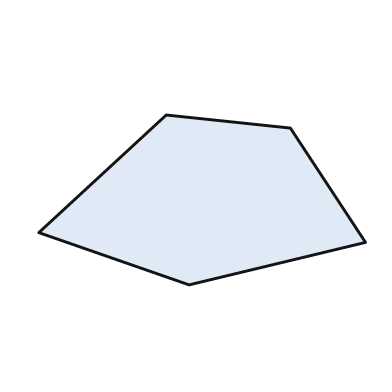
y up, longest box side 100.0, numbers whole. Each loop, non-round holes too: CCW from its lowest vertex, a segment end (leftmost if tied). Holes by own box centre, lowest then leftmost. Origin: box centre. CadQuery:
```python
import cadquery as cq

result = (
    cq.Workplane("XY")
    .moveTo(-4.0, -26.0)
    .lineTo(50.0, -13.0)
    .lineTo(27.0, 22.0)
    .lineTo(-11.0, 26.0)
    .lineTo(-50.0, -10.0)
    .close()
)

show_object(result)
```